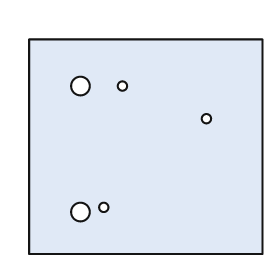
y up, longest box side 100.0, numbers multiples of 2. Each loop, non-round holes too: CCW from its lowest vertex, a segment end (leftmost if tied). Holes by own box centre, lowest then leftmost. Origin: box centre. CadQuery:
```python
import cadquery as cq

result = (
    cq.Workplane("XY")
    .moveTo(-50.0, -46.0)
    .lineTo(50.0, -46.0)
    .lineTo(50.0, 46.0)
    .lineTo(-50.0, 46.0)
    .close()
    .moveTo(-28.0, -28.0)
    .circle(4.0)
    .moveTo(-18.0, -26.0)
    .circle(2.0)
    .moveTo(26.0, 12.0)
    .circle(2.0)
    .moveTo(-28.0, 26.0)
    .circle(4.0)
    .moveTo(-10.0, 26.0)
    .circle(2.0)
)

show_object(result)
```